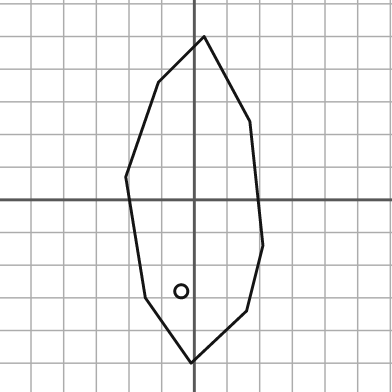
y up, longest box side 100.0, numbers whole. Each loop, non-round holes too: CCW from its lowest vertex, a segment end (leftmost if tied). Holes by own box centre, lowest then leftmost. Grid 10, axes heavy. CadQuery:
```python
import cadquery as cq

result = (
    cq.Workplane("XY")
    .moveTo(-1.0, -50.0)
    .lineTo(16.0, -34.0)
    .lineTo(21.0, -14.0)
    .lineTo(17.0, 24.0)
    .lineTo(3.0, 50.0)
    .lineTo(-11.0, 36.0)
    .lineTo(-21.0, 7.0)
    .lineTo(-15.0, -30.0)
    .close()
    .moveTo(-4.0, -28.0)
    .circle(2.0)
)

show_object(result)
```